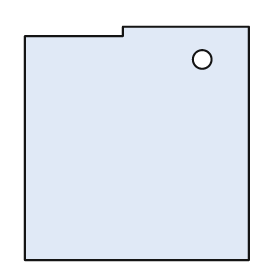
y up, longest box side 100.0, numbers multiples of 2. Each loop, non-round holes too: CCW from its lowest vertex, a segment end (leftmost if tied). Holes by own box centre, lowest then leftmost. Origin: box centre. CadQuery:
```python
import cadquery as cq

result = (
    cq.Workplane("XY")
    .moveTo(-48.0, -50.0)
    .lineTo(48.0, -50.0)
    .lineTo(48.0, 50.0)
    .lineTo(-6.0, 50.0)
    .lineTo(-6.0, 46.0)
    .lineTo(-48.0, 46.0)
    .close()
    .moveTo(28.0, 36.0)
    .circle(4.0)
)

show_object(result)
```